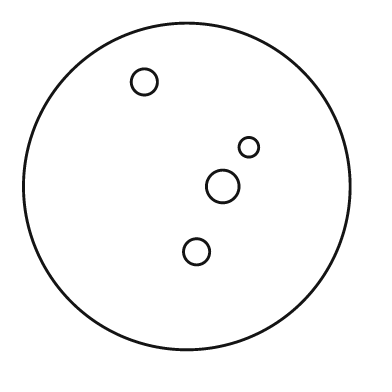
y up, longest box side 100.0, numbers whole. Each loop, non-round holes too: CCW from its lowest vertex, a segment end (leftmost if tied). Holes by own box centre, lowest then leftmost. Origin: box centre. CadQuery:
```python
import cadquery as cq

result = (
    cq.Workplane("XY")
    .moveTo(0.0, 0.0)
    .circle(50.0)
    .moveTo(3.0, -20.0)
    .circle(4.0)
    .moveTo(11.0, 0.0)
    .circle(5.0)
    .moveTo(19.0, 12.0)
    .circle(3.0)
    .moveTo(-13.0, 32.0)
    .circle(4.0)
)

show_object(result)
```